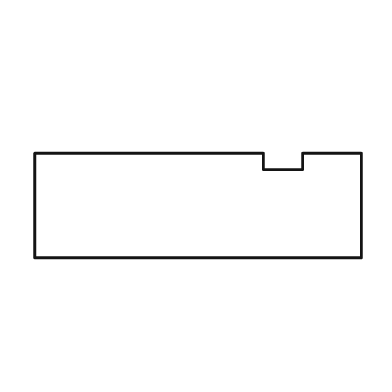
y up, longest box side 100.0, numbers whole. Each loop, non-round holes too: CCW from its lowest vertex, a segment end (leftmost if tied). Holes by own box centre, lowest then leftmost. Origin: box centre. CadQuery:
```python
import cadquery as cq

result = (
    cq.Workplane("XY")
    .moveTo(-50.0, -16.0)
    .lineTo(50.0, -16.0)
    .lineTo(50.0, 16.0)
    .lineTo(32.0, 16.0)
    .lineTo(32.0, 11.0)
    .lineTo(20.0, 11.0)
    .lineTo(20.0, 16.0)
    .lineTo(-50.0, 16.0)
    .close()
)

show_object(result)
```